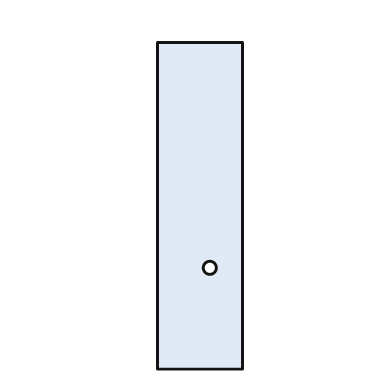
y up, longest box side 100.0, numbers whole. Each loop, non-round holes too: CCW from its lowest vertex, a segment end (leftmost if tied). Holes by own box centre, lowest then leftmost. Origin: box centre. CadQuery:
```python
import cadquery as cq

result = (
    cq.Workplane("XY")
    .moveTo(-13.0, -50.0)
    .lineTo(13.0, -50.0)
    .lineTo(13.0, 50.0)
    .lineTo(-13.0, 50.0)
    .close()
    .moveTo(3.0, -19.0)
    .circle(2.0)
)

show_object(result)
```